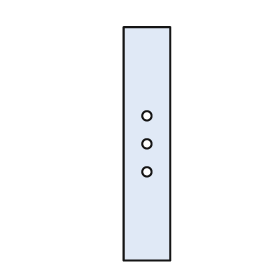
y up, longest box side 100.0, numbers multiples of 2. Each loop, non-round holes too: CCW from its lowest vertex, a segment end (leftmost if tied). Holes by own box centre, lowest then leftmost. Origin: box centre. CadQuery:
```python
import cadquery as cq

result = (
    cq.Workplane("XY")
    .moveTo(-10.0, -50.0)
    .lineTo(10.0, -50.0)
    .lineTo(10.0, 50.0)
    .lineTo(-10.0, 50.0)
    .close()
    .moveTo(0.0, -12.0)
    .circle(2.0)
    .moveTo(0.0, 0.0)
    .circle(2.0)
    .moveTo(0.0, 12.0)
    .circle(2.0)
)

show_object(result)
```